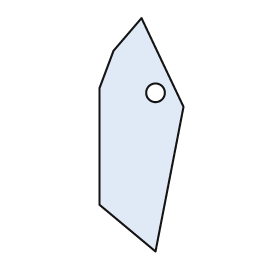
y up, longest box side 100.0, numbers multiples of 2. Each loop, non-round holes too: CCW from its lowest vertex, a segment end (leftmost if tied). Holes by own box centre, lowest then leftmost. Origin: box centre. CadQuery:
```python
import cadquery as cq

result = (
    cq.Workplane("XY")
    .moveTo(6.0, -50.0)
    .lineTo(18.0, 12.0)
    .lineTo(0.0, 50.0)
    .lineTo(-12.0, 36.0)
    .lineTo(-18.0, 20.0)
    .lineTo(-18.0, -30.0)
    .close()
    .moveTo(6.0, 18.0)
    .circle(4.0)
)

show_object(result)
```